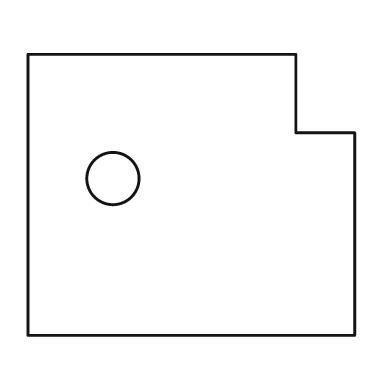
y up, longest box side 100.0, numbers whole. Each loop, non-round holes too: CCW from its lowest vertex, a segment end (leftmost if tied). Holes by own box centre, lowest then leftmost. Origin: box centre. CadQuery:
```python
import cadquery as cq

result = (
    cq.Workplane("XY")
    .moveTo(-50.0, -43.0)
    .lineTo(50.0, -43.0)
    .lineTo(50.0, 19.0)
    .lineTo(32.0, 19.0)
    .lineTo(32.0, 43.0)
    .lineTo(-50.0, 43.0)
    .close()
    .moveTo(-24.0, 5.0)
    .circle(8.0)
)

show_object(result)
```